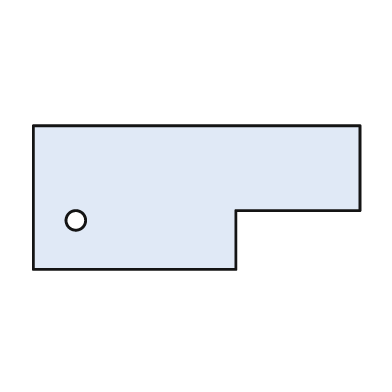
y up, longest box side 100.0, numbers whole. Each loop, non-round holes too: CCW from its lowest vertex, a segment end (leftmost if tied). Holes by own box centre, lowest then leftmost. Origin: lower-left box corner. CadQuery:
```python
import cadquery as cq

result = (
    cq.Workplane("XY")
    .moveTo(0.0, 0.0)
    .lineTo(62.0, 0.0)
    .lineTo(62.0, 18.0)
    .lineTo(100.0, 18.0)
    .lineTo(100.0, 44.0)
    .lineTo(0.0, 44.0)
    .close()
    .moveTo(13.0, 15.0)
    .circle(3.0)
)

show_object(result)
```